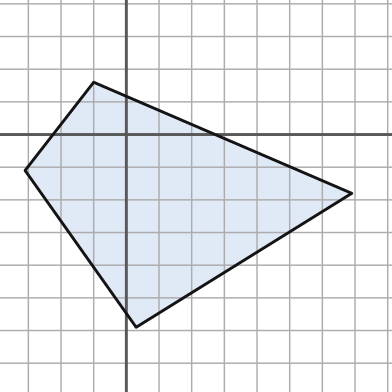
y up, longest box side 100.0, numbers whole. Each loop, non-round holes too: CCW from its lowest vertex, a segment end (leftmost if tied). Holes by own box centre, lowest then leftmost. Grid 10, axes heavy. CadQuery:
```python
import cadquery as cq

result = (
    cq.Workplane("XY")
    .moveTo(3.0, -59.0)
    .lineTo(69.0, -18.0)
    .lineTo(-10.0, 16.0)
    .lineTo(-31.0, -11.0)
    .close()
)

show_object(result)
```